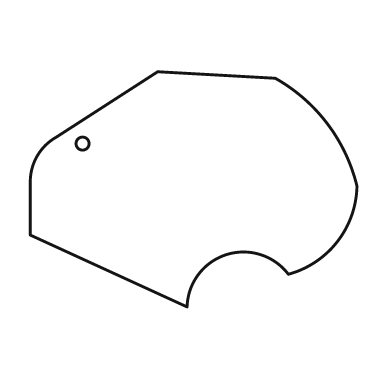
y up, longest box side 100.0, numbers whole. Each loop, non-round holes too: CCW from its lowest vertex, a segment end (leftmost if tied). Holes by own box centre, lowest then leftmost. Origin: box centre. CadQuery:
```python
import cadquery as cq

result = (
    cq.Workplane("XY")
    .moveTo(-2.0, -36.0)
    .threePointArc((10.0, -20.0), (29.0, -26.0))
    .threePointArc((44.0, -16.0), (50.0, 1.0))
    .threePointArc((41.0, 20.0), (25.0, 34.0))
    .lineTo(-11.0, 36.0)
    .lineTo(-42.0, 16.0)
    .threePointArc((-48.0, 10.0), (-50.0, 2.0))
    .lineTo(-50.0, -14.0)
    .close()
    .moveTo(-34.0, 14.0)
    .circle(2.0)
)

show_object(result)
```